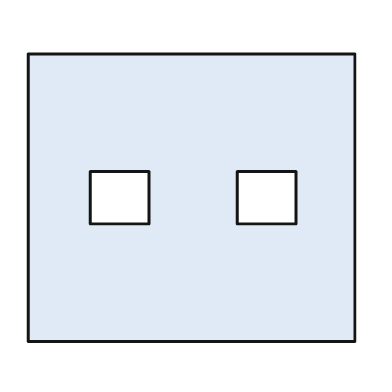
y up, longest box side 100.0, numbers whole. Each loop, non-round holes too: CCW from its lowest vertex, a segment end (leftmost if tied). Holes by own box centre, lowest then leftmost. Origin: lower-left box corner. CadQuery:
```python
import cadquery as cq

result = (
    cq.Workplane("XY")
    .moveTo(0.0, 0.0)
    .lineTo(100.0, 0.0)
    .lineTo(100.0, 88.0)
    .lineTo(0.0, 88.0)
    .close()
    .moveTo(19.0, 36.0)
    .lineTo(37.0, 36.0)
    .lineTo(37.0, 52.0)
    .lineTo(19.0, 52.0)
    .close()
    .moveTo(64.0, 36.0)
    .lineTo(82.0, 36.0)
    .lineTo(82.0, 52.0)
    .lineTo(64.0, 52.0)
    .close()
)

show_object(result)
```